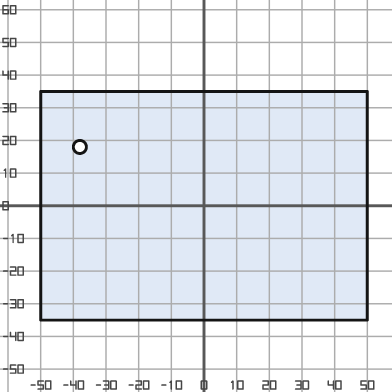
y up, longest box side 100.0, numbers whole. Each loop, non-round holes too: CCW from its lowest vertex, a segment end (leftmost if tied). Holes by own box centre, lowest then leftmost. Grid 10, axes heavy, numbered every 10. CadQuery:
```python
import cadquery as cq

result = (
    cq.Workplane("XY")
    .moveTo(-50.0, -35.0)
    .lineTo(50.0, -35.0)
    .lineTo(50.0, 35.0)
    .lineTo(-50.0, 35.0)
    .close()
    .moveTo(-38.0, 18.0)
    .circle(2.0)
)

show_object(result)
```